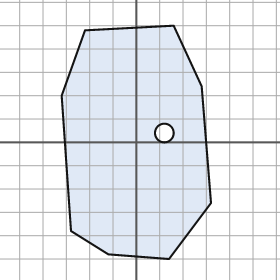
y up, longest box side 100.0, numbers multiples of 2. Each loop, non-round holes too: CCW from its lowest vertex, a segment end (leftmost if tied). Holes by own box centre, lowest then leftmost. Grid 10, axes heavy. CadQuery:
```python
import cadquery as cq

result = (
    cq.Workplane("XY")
    .moveTo(14.0, -50.0)
    .lineTo(32.0, -26.0)
    .lineTo(28.0, 24.0)
    .lineTo(16.0, 50.0)
    .lineTo(-22.0, 48.0)
    .lineTo(-32.0, 20.0)
    .lineTo(-28.0, -38.0)
    .lineTo(-12.0, -48.0)
    .close()
    .moveTo(12.0, 4.0)
    .circle(4.0)
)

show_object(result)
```